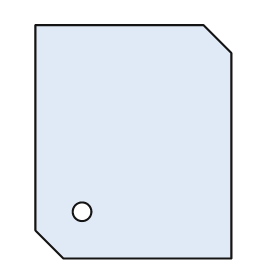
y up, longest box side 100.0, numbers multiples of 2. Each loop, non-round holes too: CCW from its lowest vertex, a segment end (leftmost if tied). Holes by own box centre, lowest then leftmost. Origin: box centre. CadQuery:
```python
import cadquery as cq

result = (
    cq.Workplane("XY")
    .moveTo(-30.0, -50.0)
    .lineTo(42.0, -50.0)
    .lineTo(42.0, 38.0)
    .lineTo(30.0, 50.0)
    .lineTo(-42.0, 50.0)
    .lineTo(-42.0, -38.0)
    .close()
    .moveTo(-22.0, -30.0)
    .circle(4.0)
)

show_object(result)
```